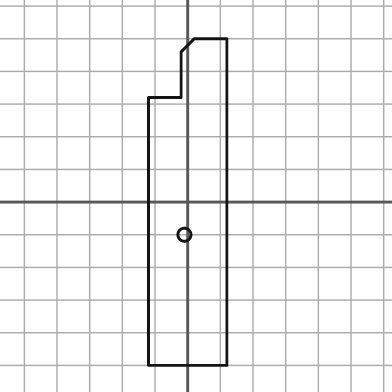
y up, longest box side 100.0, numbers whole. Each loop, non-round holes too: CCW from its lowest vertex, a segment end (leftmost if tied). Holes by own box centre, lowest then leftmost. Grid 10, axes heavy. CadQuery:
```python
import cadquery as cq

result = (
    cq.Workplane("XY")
    .moveTo(-12.0, -50.0)
    .lineTo(12.0, -50.0)
    .lineTo(12.0, 50.0)
    .lineTo(2.0, 50.0)
    .lineTo(-2.0, 46.0)
    .lineTo(-2.0, 32.0)
    .lineTo(-12.0, 32.0)
    .close()
    .moveTo(-1.0, -10.0)
    .circle(2.0)
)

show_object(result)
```